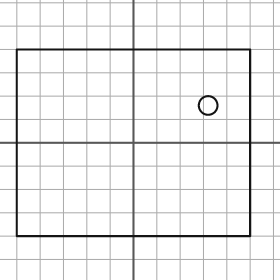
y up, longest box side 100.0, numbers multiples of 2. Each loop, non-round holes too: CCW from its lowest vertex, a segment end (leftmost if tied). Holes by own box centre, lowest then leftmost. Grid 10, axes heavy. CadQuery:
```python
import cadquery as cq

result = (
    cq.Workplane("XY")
    .moveTo(-50.0, -40.0)
    .lineTo(50.0, -40.0)
    .lineTo(50.0, 40.0)
    .lineTo(-50.0, 40.0)
    .close()
    .moveTo(32.0, 16.0)
    .circle(4.0)
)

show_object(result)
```